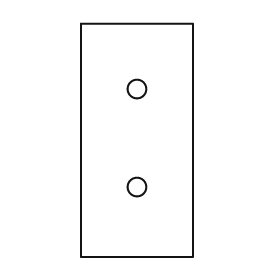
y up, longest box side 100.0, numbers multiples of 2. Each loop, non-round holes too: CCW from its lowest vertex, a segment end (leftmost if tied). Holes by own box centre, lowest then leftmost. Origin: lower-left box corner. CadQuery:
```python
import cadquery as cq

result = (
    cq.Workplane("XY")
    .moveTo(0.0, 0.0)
    .lineTo(48.0, 0.0)
    .lineTo(48.0, 100.0)
    .lineTo(0.0, 100.0)
    .close()
    .moveTo(24.0, 30.0)
    .circle(4.0)
    .moveTo(24.0, 72.0)
    .circle(4.0)
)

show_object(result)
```